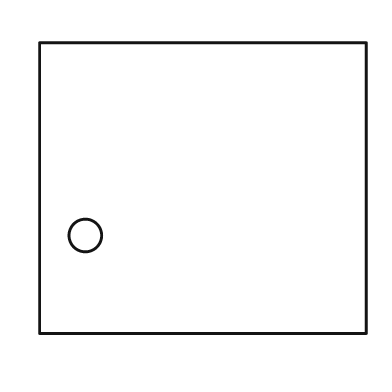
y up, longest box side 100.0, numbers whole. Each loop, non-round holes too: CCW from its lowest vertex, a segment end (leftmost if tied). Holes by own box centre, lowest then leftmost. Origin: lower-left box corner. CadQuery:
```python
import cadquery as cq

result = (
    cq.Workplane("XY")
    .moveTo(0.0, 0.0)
    .lineTo(100.0, 0.0)
    .lineTo(100.0, 89.0)
    .lineTo(0.0, 89.0)
    .close()
    .moveTo(14.0, 30.0)
    .circle(5.0)
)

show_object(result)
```